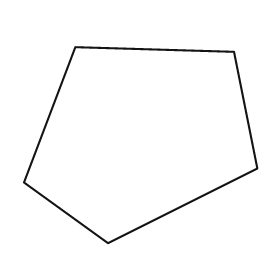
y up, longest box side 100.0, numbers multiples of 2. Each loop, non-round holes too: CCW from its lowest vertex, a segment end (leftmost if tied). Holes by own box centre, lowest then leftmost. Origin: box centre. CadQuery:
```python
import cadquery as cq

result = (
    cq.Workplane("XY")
    .moveTo(-14.0, -42.0)
    .lineTo(50.0, -10.0)
    .lineTo(40.0, 40.0)
    .lineTo(-28.0, 42.0)
    .lineTo(-50.0, -16.0)
    .close()
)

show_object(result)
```